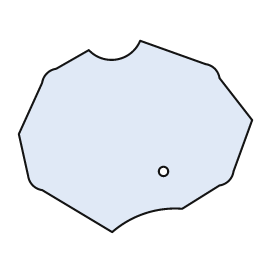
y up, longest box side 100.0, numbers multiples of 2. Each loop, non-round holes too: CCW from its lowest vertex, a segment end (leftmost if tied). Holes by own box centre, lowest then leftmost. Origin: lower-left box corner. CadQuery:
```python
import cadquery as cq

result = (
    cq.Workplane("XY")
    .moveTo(40.0, 0.0)
    .threePointArc((54.0, 8.0), (70.0, 10.0))
    .lineTo(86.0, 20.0)
    .threePointArc((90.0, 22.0), (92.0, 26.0))
    .lineTo(100.0, 48.0)
    .lineTo(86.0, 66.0)
    .threePointArc((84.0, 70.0), (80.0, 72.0))
    .lineTo(52.0, 82.0)
    .threePointArc((42.0, 74.0), (30.0, 78.0))
    .lineTo(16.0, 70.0)
    .threePointArc((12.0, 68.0), (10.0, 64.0))
    .lineTo(0.0, 42.0)
    .lineTo(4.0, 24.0)
    .threePointArc((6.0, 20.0), (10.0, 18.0))
    .close()
    .moveTo(62.0, 26.0)
    .circle(2.0)
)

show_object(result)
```